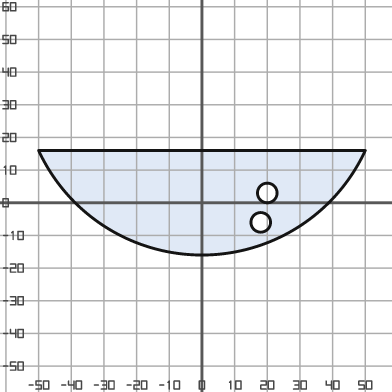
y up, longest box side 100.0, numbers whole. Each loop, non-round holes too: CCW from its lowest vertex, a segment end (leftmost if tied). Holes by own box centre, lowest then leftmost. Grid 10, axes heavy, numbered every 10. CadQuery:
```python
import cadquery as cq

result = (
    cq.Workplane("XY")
    .moveTo(-50.0, 16.0)
    .threePointArc((0.0, -16.0), (50.0, 16.0))
    .close()
    .moveTo(18.0, -6.0)
    .circle(3.0)
    .moveTo(20.0, 3.0)
    .circle(3.0)
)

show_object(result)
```